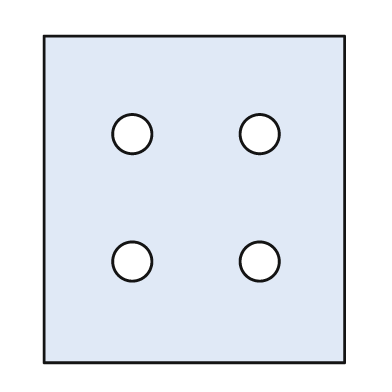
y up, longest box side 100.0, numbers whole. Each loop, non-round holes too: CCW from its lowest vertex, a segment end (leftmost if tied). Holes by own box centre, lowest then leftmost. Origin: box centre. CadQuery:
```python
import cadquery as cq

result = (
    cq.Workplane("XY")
    .moveTo(-46.0, -50.0)
    .lineTo(46.0, -50.0)
    .lineTo(46.0, 50.0)
    .lineTo(-46.0, 50.0)
    .close()
    .moveTo(-19.0, -19.0)
    .circle(6.0)
    .moveTo(20.0, -19.0)
    .circle(6.0)
    .moveTo(-19.0, 20.0)
    .circle(6.0)
    .moveTo(20.0, 20.0)
    .circle(6.0)
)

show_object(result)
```